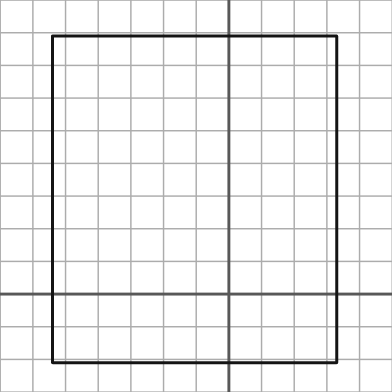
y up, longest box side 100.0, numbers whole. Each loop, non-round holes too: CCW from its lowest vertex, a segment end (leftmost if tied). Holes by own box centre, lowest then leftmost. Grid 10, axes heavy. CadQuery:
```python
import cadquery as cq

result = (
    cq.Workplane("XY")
    .moveTo(-54.0, -21.0)
    .lineTo(33.0, -21.0)
    .lineTo(33.0, 79.0)
    .lineTo(-54.0, 79.0)
    .close()
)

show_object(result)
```